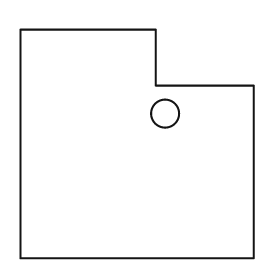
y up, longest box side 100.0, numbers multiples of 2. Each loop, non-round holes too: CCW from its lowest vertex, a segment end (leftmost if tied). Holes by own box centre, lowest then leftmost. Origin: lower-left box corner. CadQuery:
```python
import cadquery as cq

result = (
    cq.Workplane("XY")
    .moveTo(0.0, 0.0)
    .lineTo(100.0, 0.0)
    .lineTo(100.0, 74.0)
    .lineTo(58.0, 74.0)
    .lineTo(58.0, 98.0)
    .lineTo(0.0, 98.0)
    .close()
    .moveTo(62.0, 62.0)
    .circle(6.0)
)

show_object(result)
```